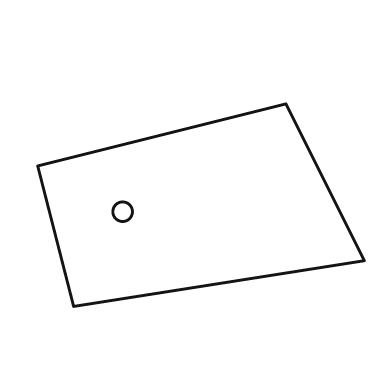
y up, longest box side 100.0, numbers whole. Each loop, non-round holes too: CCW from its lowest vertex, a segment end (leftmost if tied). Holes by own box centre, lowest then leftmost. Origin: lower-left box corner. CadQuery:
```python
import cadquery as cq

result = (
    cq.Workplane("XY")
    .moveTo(11.0, 0.0)
    .lineTo(100.0, 14.0)
    .lineTo(76.0, 62.0)
    .lineTo(0.0, 43.0)
    .close()
    .moveTo(26.0, 29.0)
    .circle(3.0)
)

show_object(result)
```